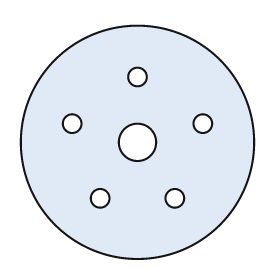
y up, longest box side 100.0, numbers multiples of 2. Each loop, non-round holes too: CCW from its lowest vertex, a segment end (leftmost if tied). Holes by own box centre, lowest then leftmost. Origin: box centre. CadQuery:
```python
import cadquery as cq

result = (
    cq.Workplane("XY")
    .moveTo(0.0, 0.0)
    .circle(50.0)
    .moveTo(-16.0, -24.0)
    .circle(4.0)
    .moveTo(16.0, -24.0)
    .circle(4.0)
    .moveTo(0.0, 0.0)
    .circle(8.0)
    .moveTo(-28.0, 8.0)
    .circle(4.0)
    .moveTo(28.0, 8.0)
    .circle(4.0)
    .moveTo(0.0, 28.0)
    .circle(4.0)
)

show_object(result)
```